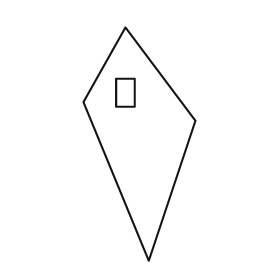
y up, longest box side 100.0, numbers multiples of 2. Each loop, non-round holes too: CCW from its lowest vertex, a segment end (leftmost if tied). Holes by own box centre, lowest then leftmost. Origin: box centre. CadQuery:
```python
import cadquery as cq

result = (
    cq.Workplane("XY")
    .moveTo(4.0, -50.0)
    .lineTo(24.0, 10.0)
    .lineTo(-6.0, 50.0)
    .lineTo(-24.0, 18.0)
    .close()
    .moveTo(-10.0, 16.0)
    .lineTo(-2.0, 16.0)
    .lineTo(-2.0, 28.0)
    .lineTo(-10.0, 28.0)
    .close()
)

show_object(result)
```